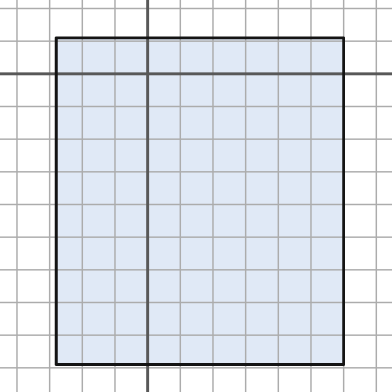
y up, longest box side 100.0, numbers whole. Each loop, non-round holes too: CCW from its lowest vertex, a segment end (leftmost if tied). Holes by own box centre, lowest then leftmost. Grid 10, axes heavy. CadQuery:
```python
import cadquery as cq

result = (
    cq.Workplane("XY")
    .moveTo(-28.0, -89.0)
    .lineTo(60.0, -89.0)
    .lineTo(60.0, 11.0)
    .lineTo(-28.0, 11.0)
    .close()
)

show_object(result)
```